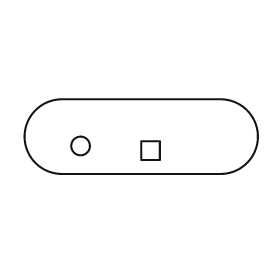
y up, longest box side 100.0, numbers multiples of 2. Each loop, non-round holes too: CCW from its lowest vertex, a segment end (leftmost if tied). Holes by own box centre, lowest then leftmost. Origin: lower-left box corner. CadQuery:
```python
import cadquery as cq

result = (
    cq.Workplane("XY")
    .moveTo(16.0, 0.0)
    .lineTo(84.0, 0.0)
    .threePointArc((100.0, 16.0), (84.0, 32.0))
    .lineTo(16.0, 32.0)
    .threePointArc((0.0, 16.0), (16.0, 0.0))
    .close()
    .moveTo(50.0, 6.0)
    .lineTo(58.0, 6.0)
    .lineTo(58.0, 14.0)
    .lineTo(50.0, 14.0)
    .close()
    .moveTo(24.0, 12.0)
    .circle(4.0)
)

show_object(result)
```